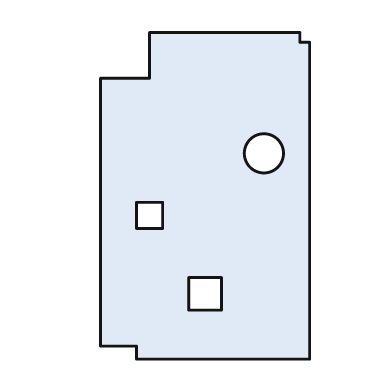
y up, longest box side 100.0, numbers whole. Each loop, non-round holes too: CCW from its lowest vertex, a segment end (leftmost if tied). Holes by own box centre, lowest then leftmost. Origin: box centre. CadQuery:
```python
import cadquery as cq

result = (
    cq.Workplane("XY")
    .moveTo(-21.0, -50.0)
    .lineTo(32.0, -50.0)
    .lineTo(32.0, 47.0)
    .lineTo(29.0, 47.0)
    .lineTo(29.0, 50.0)
    .lineTo(-17.0, 50.0)
    .lineTo(-17.0, 36.0)
    .lineTo(-32.0, 36.0)
    .lineTo(-32.0, -46.0)
    .lineTo(-21.0, -46.0)
    .close()
    .moveTo(-5.0, -35.0)
    .lineTo(5.0, -35.0)
    .lineTo(5.0, -25.0)
    .lineTo(-5.0, -25.0)
    .close()
    .moveTo(-21.0, -10.0)
    .lineTo(-13.0, -10.0)
    .lineTo(-13.0, -2.0)
    .lineTo(-21.0, -2.0)
    .close()
    .moveTo(18.0, 13.0)
    .circle(6.0)
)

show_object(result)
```